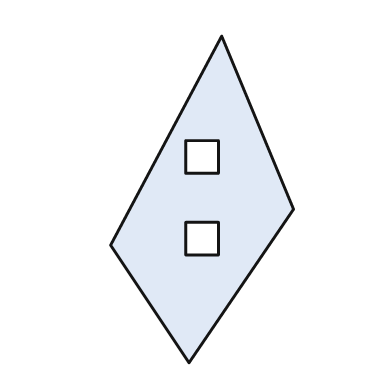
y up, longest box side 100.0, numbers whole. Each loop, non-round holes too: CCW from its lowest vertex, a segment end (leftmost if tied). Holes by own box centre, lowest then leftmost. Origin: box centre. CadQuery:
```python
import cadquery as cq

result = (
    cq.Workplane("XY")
    .moveTo(-4.0, -50.0)
    .lineTo(28.0, -3.0)
    .lineTo(6.0, 50.0)
    .lineTo(-28.0, -14.0)
    .close()
    .moveTo(-5.0, -17.0)
    .lineTo(5.0, -17.0)
    .lineTo(5.0, -7.0)
    .lineTo(-5.0, -7.0)
    .close()
    .moveTo(-5.0, 8.0)
    .lineTo(5.0, 8.0)
    .lineTo(5.0, 18.0)
    .lineTo(-5.0, 18.0)
    .close()
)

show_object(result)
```